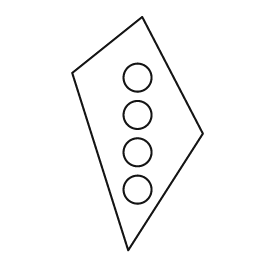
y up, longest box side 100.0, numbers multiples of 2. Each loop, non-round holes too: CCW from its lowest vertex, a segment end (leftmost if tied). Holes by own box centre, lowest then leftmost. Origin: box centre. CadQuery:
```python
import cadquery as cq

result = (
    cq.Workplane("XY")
    .moveTo(-4.0, -50.0)
    .lineTo(28.0, 0.0)
    .lineTo(2.0, 50.0)
    .lineTo(-28.0, 26.0)
    .close()
    .moveTo(0.0, -24.0)
    .circle(6.0)
    .moveTo(0.0, -8.0)
    .circle(6.0)
    .moveTo(0.0, 8.0)
    .circle(6.0)
    .moveTo(0.0, 24.0)
    .circle(6.0)
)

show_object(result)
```